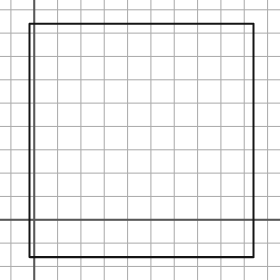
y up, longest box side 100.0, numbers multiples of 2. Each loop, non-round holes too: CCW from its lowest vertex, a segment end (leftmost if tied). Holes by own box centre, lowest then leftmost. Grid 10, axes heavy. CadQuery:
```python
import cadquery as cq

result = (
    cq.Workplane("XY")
    .moveTo(-2.0, -16.0)
    .lineTo(94.0, -16.0)
    .lineTo(94.0, 84.0)
    .lineTo(-2.0, 84.0)
    .close()
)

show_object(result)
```